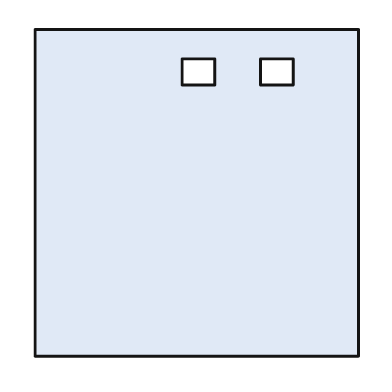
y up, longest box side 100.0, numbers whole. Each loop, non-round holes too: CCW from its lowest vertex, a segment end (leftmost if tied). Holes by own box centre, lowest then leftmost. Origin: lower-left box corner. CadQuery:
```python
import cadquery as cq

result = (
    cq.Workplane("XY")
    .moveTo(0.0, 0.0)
    .lineTo(99.0, 0.0)
    .lineTo(99.0, 100.0)
    .lineTo(0.0, 100.0)
    .close()
    .moveTo(45.0, 83.0)
    .lineTo(55.0, 83.0)
    .lineTo(55.0, 91.0)
    .lineTo(45.0, 91.0)
    .close()
    .moveTo(69.0, 83.0)
    .lineTo(79.0, 83.0)
    .lineTo(79.0, 91.0)
    .lineTo(69.0, 91.0)
    .close()
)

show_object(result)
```